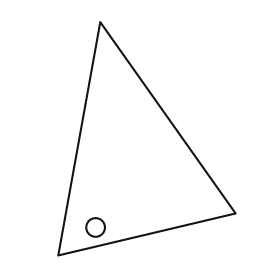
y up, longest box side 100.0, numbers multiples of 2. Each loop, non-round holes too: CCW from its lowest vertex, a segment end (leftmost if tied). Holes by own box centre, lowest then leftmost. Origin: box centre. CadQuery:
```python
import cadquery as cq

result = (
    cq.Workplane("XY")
    .moveTo(-38.0, -50.0)
    .lineTo(38.0, -32.0)
    .lineTo(-20.0, 50.0)
    .close()
    .moveTo(-22.0, -38.0)
    .circle(4.0)
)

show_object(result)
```